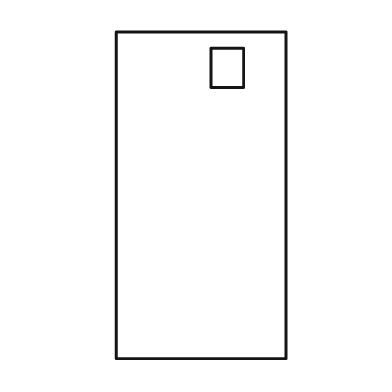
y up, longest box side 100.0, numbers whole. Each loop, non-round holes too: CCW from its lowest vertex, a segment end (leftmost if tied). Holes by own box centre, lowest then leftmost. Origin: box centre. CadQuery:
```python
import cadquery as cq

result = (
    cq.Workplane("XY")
    .moveTo(-26.0, -50.0)
    .lineTo(26.0, -50.0)
    .lineTo(26.0, 50.0)
    .lineTo(-26.0, 50.0)
    .close()
    .moveTo(3.0, 33.0)
    .lineTo(13.0, 33.0)
    .lineTo(13.0, 45.0)
    .lineTo(3.0, 45.0)
    .close()
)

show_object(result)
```